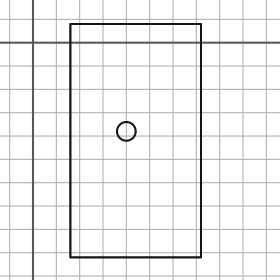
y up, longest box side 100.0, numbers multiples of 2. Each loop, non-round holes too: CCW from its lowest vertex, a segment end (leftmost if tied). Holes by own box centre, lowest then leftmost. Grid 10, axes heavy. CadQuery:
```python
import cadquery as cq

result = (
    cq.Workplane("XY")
    .moveTo(16.0, -92.0)
    .lineTo(72.0, -92.0)
    .lineTo(72.0, 8.0)
    .lineTo(16.0, 8.0)
    .close()
    .moveTo(40.0, -38.0)
    .circle(4.0)
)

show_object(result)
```